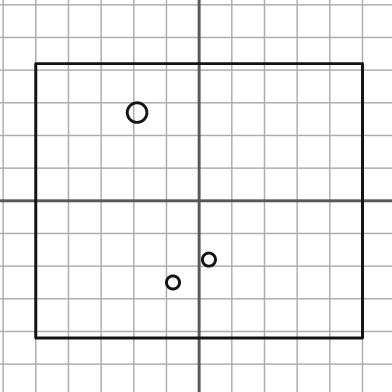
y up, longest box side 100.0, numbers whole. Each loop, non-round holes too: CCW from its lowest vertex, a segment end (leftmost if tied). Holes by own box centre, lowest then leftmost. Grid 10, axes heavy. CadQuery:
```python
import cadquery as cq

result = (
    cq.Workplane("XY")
    .moveTo(-50.0, -42.0)
    .lineTo(50.0, -42.0)
    .lineTo(50.0, 42.0)
    .lineTo(-50.0, 42.0)
    .close()
    .moveTo(-8.0, -25.0)
    .circle(2.0)
    .moveTo(3.0, -18.0)
    .circle(2.0)
    .moveTo(-19.0, 27.0)
    .circle(3.0)
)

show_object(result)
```